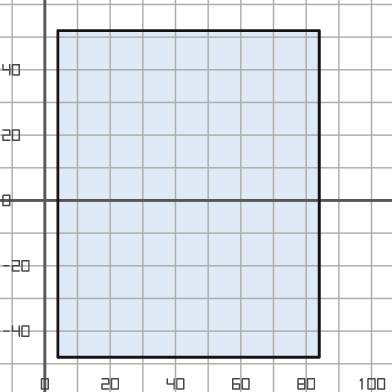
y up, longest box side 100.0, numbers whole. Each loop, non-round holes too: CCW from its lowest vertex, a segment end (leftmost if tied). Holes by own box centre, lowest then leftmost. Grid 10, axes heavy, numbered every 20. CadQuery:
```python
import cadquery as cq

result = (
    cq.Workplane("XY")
    .moveTo(4.0, -48.0)
    .lineTo(84.0, -48.0)
    .lineTo(84.0, 52.0)
    .lineTo(4.0, 52.0)
    .close()
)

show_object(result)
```